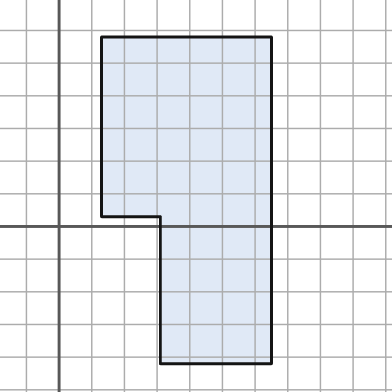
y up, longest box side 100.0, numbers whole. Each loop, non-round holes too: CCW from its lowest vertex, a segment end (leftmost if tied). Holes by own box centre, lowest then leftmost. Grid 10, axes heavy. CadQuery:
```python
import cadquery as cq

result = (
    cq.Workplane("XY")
    .moveTo(31.0, -42.0)
    .lineTo(65.0, -42.0)
    .lineTo(65.0, 58.0)
    .lineTo(13.0, 58.0)
    .lineTo(13.0, 3.0)
    .lineTo(31.0, 3.0)
    .close()
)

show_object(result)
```